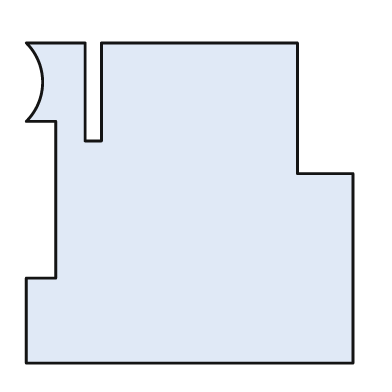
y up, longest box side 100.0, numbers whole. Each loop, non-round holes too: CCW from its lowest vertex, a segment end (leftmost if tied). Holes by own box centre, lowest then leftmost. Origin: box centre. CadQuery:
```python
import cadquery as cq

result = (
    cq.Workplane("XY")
    .moveTo(-50.0, -49.0)
    .lineTo(50.0, -49.0)
    .lineTo(50.0, 9.0)
    .lineTo(33.0, 9.0)
    .lineTo(33.0, 49.0)
    .lineTo(-27.0, 49.0)
    .lineTo(-27.0, 19.0)
    .lineTo(-32.0, 19.0)
    .lineTo(-32.0, 49.0)
    .lineTo(-50.0, 49.0)
    .threePointArc((-45.0, 37.0), (-50.0, 25.0))
    .lineTo(-41.0, 25.0)
    .lineTo(-41.0, -23.0)
    .lineTo(-50.0, -23.0)
    .close()
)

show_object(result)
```